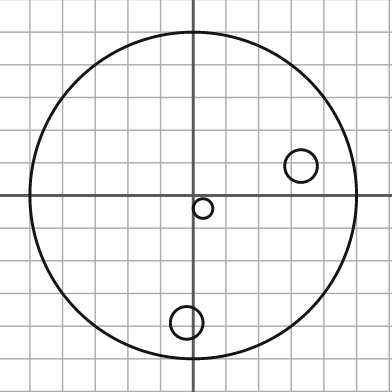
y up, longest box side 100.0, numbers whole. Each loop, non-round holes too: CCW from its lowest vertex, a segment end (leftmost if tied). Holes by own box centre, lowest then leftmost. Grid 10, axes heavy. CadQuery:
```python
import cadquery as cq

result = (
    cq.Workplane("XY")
    .moveTo(0.0, 0.0)
    .circle(50.0)
    .moveTo(-2.0, -39.0)
    .circle(5.0)
    .moveTo(3.0, -4.0)
    .circle(3.0)
    .moveTo(33.0, 9.0)
    .circle(5.0)
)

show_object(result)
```